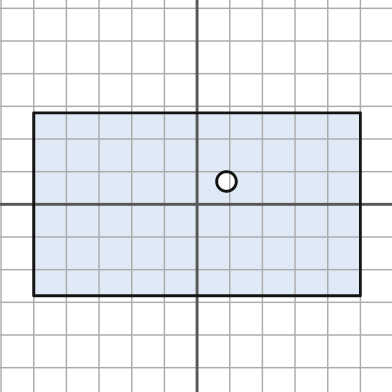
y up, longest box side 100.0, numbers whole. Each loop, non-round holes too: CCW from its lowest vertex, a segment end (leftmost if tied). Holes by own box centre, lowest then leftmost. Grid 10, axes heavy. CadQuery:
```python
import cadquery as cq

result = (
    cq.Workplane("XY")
    .moveTo(-50.0, -28.0)
    .lineTo(50.0, -28.0)
    .lineTo(50.0, 28.0)
    .lineTo(-50.0, 28.0)
    .close()
    .moveTo(9.0, 7.0)
    .circle(3.0)
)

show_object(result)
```